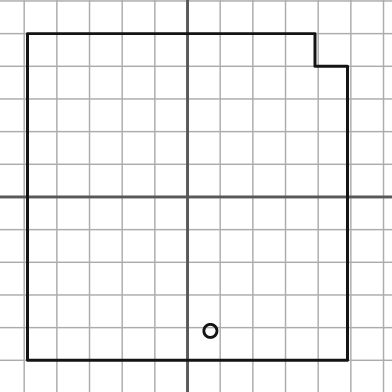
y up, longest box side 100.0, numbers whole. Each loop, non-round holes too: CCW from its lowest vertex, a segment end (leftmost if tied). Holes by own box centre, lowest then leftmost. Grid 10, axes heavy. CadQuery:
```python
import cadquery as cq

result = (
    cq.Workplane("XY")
    .moveTo(-49.0, -50.0)
    .lineTo(49.0, -50.0)
    .lineTo(49.0, 40.0)
    .lineTo(39.0, 40.0)
    .lineTo(39.0, 50.0)
    .lineTo(-49.0, 50.0)
    .close()
    .moveTo(7.0, -41.0)
    .circle(2.0)
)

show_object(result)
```